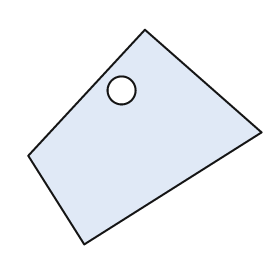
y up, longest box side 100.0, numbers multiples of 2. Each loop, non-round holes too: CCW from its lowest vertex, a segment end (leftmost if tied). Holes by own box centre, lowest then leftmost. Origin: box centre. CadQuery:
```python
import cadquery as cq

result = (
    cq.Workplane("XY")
    .moveTo(-26.0, -46.0)
    .lineTo(50.0, 2.0)
    .lineTo(0.0, 46.0)
    .lineTo(-50.0, -8.0)
    .close()
    .moveTo(-10.0, 20.0)
    .circle(6.0)
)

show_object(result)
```